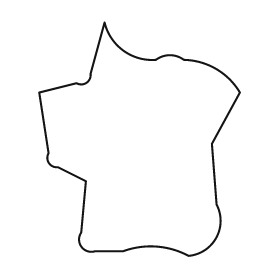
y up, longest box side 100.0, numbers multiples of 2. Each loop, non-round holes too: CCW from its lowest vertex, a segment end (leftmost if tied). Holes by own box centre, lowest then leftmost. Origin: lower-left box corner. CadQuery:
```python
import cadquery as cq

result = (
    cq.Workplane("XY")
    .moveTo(64.0, 0.0)
    .threePointArc((76.0, 8.0), (76.0, 22.0))
    .lineTo(74.0, 48.0)
    .lineTo(86.0, 70.0)
    .threePointArc((76.0, 80.0), (62.0, 84.0))
    .threePointArc((56.0, 86.0), (50.0, 84.0))
    .threePointArc((36.0, 88.0), (28.0, 100.0))
    .lineTo(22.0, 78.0)
    .threePointArc((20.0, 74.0), (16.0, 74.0))
    .lineTo(0.0, 70.0)
    .lineTo(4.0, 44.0)
    .threePointArc((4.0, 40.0), (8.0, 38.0))
    .lineTo(20.0, 32.0)
    .lineTo(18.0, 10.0)
    .threePointArc((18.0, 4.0), (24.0, 2.0))
    .lineTo(36.0, 2.0)
    .threePointArc((50.0, 4.0), (64.0, 0.0))
    .close()
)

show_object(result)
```